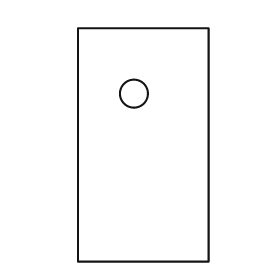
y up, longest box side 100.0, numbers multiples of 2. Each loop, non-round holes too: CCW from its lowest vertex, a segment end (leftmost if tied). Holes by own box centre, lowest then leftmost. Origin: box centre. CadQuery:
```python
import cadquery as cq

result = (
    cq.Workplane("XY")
    .moveTo(-28.0, -50.0)
    .lineTo(28.0, -50.0)
    .lineTo(28.0, 50.0)
    .lineTo(-28.0, 50.0)
    .close()
    .moveTo(-4.0, 22.0)
    .circle(6.0)
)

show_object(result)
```